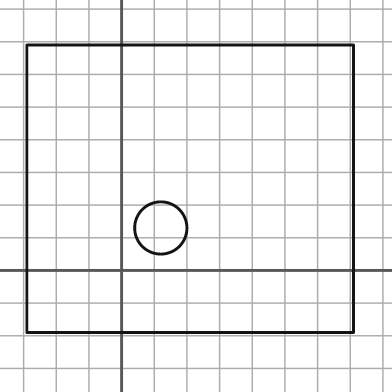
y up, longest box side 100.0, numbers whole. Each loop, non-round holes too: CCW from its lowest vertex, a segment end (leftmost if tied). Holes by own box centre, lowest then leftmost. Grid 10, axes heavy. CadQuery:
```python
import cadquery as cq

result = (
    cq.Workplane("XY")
    .moveTo(-29.0, -19.0)
    .lineTo(71.0, -19.0)
    .lineTo(71.0, 69.0)
    .lineTo(-29.0, 69.0)
    .close()
    .moveTo(12.0, 13.0)
    .circle(8.0)
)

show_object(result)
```